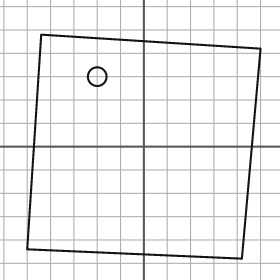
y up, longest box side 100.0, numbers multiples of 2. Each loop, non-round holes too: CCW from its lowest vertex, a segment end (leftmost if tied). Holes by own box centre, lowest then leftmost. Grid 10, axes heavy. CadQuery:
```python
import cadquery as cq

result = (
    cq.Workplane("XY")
    .moveTo(42.0, -48.0)
    .lineTo(50.0, 42.0)
    .lineTo(-44.0, 48.0)
    .lineTo(-50.0, -44.0)
    .close()
    .moveTo(-20.0, 30.0)
    .circle(4.0)
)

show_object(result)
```